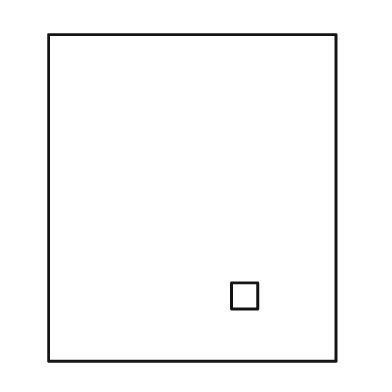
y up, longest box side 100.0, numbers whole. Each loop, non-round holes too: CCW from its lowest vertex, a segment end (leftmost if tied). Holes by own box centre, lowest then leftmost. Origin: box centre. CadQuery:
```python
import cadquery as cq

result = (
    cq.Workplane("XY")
    .moveTo(-44.0, -50.0)
    .lineTo(44.0, -50.0)
    .lineTo(44.0, 50.0)
    .lineTo(-44.0, 50.0)
    .close()
    .moveTo(12.0, -34.0)
    .lineTo(20.0, -34.0)
    .lineTo(20.0, -26.0)
    .lineTo(12.0, -26.0)
    .close()
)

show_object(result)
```